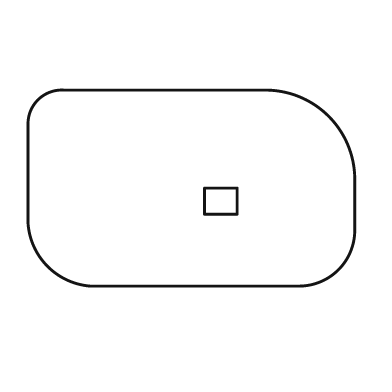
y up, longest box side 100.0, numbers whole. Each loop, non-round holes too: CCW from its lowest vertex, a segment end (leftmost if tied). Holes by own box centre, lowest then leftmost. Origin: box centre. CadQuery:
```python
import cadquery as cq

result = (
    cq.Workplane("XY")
    .moveTo(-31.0, -30.0)
    .lineTo(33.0, -30.0)
    .threePointArc((45.0, -25.0), (50.0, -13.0))
    .lineTo(50.0, 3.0)
    .threePointArc((42.0, 22.0), (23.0, 30.0))
    .lineTo(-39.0, 30.0)
    .threePointArc((-47.0, 27.0), (-50.0, 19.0))
    .lineTo(-50.0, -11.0)
    .threePointArc((-44.0, -24.0), (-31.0, -30.0))
    .close()
    .moveTo(4.0, -8.0)
    .lineTo(14.0, -8.0)
    .lineTo(14.0, 0.0)
    .lineTo(4.0, 0.0)
    .close()
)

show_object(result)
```